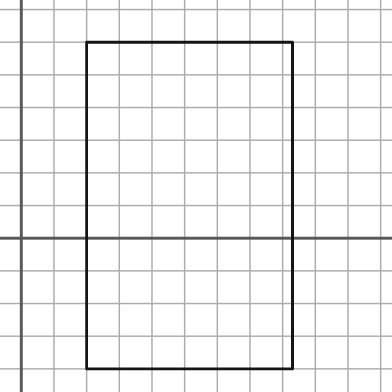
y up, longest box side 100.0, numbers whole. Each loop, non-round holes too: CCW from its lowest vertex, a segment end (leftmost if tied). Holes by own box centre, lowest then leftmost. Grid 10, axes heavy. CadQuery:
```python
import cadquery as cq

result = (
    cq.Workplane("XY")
    .moveTo(20.0, -40.0)
    .lineTo(83.0, -40.0)
    .lineTo(83.0, 60.0)
    .lineTo(20.0, 60.0)
    .close()
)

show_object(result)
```